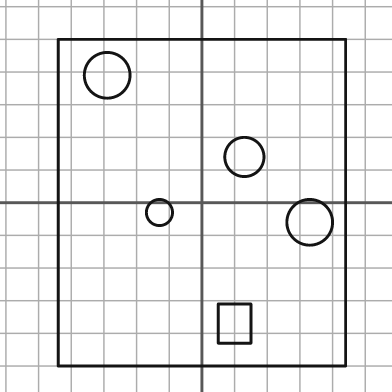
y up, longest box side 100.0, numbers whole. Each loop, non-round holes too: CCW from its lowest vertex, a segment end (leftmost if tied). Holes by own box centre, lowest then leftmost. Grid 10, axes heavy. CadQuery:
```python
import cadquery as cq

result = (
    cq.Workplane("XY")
    .moveTo(-44.0, -50.0)
    .lineTo(44.0, -50.0)
    .lineTo(44.0, 50.0)
    .lineTo(-44.0, 50.0)
    .close()
    .moveTo(5.0, -43.0)
    .lineTo(15.0, -43.0)
    .lineTo(15.0, -31.0)
    .lineTo(5.0, -31.0)
    .close()
    .moveTo(33.0, -6.0)
    .circle(7.0)
    .moveTo(-13.0, -3.0)
    .circle(4.0)
    .moveTo(13.0, 14.0)
    .circle(6.0)
    .moveTo(-29.0, 39.0)
    .circle(7.0)
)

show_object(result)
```